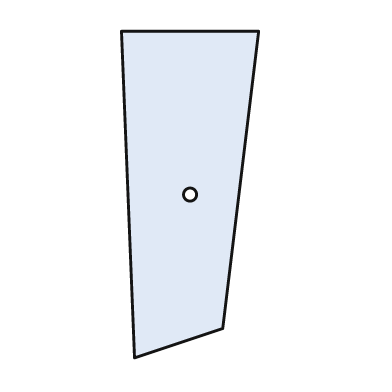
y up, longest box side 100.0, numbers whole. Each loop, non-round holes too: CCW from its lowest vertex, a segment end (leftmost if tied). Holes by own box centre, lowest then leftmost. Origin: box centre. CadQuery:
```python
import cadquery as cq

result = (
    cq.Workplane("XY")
    .moveTo(-17.0, -50.0)
    .lineTo(10.0, -41.0)
    .lineTo(21.0, 50.0)
    .lineTo(-21.0, 50.0)
    .close()
    .moveTo(0.0, 0.0)
    .circle(2.0)
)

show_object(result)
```